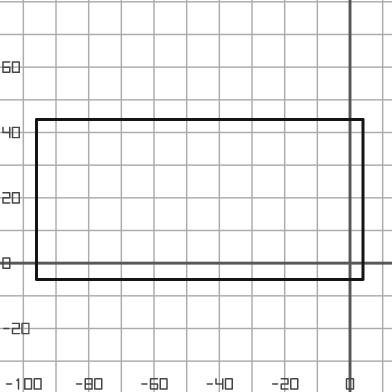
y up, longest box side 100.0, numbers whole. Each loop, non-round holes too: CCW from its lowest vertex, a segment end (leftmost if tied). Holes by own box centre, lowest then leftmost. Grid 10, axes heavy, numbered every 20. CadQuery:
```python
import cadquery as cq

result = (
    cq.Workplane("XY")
    .moveTo(-96.0, -5.0)
    .lineTo(4.0, -5.0)
    .lineTo(4.0, 44.0)
    .lineTo(-96.0, 44.0)
    .close()
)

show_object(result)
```